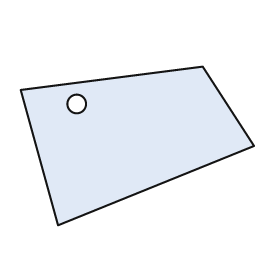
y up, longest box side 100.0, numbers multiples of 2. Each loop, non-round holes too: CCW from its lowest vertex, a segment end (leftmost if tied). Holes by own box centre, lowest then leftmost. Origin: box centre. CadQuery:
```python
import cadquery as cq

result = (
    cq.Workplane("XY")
    .moveTo(-34.0, -34.0)
    .lineTo(50.0, 0.0)
    .lineTo(28.0, 34.0)
    .lineTo(-50.0, 24.0)
    .close()
    .moveTo(-26.0, 18.0)
    .circle(4.0)
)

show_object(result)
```